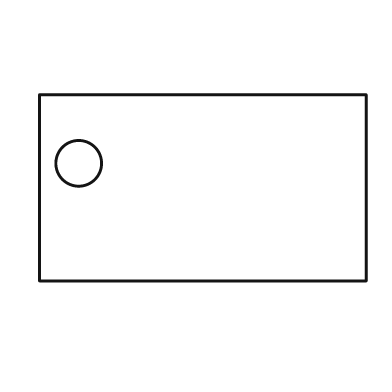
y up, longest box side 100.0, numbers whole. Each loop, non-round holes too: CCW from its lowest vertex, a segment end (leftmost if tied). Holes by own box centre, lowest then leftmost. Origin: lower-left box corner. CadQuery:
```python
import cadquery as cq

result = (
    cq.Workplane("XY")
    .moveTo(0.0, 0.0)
    .lineTo(100.0, 0.0)
    .lineTo(100.0, 57.0)
    .lineTo(0.0, 57.0)
    .close()
    .moveTo(12.0, 36.0)
    .circle(7.0)
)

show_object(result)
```